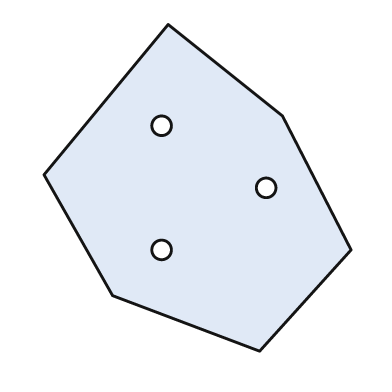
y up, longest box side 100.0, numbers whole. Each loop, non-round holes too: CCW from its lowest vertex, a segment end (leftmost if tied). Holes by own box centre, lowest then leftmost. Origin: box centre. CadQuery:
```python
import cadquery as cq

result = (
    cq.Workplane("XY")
    .moveTo(19.0, -50.0)
    .lineTo(47.0, -19.0)
    .lineTo(26.0, 22.0)
    .lineTo(-9.0, 50.0)
    .lineTo(-47.0, 4.0)
    .lineTo(-26.0, -33.0)
    .close()
    .moveTo(-11.0, -19.0)
    .circle(3.0)
    .moveTo(21.0, 0.0)
    .circle(3.0)
    .moveTo(-11.0, 19.0)
    .circle(3.0)
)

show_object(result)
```